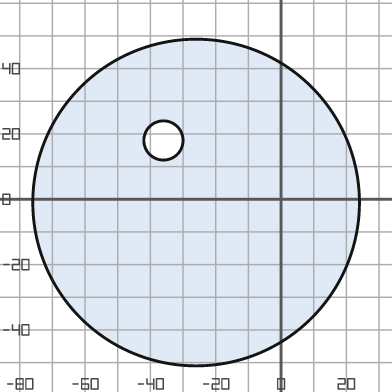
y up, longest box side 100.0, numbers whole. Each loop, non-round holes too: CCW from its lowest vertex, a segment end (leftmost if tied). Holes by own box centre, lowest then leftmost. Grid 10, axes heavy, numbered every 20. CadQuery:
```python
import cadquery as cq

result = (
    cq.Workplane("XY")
    .moveTo(-26.0, -1.0)
    .circle(50.0)
    .moveTo(-36.0, 18.0)
    .circle(6.0)
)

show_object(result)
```